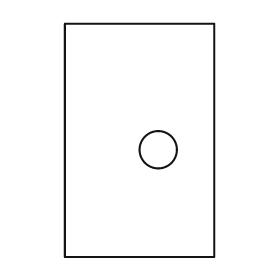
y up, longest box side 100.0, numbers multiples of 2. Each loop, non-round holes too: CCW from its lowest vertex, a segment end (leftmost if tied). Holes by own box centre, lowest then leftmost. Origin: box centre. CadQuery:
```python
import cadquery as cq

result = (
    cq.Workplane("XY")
    .moveTo(-32.0, -50.0)
    .lineTo(32.0, -50.0)
    .lineTo(32.0, 50.0)
    .lineTo(-32.0, 50.0)
    .close()
    .moveTo(8.0, -4.0)
    .circle(8.0)
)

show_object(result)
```